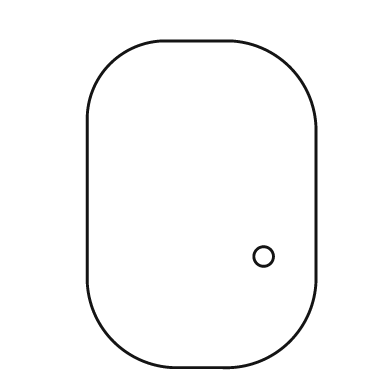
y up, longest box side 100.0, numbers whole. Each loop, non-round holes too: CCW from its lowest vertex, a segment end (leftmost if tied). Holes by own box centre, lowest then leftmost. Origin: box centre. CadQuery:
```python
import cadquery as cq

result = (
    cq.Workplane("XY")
    .moveTo(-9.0, -50.0)
    .lineTo(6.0, -50.0)
    .threePointArc((27.0, -42.0), (35.0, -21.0))
    .lineTo(35.0, 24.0)
    .threePointArc((27.0, 42.0), (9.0, 50.0))
    .lineTo(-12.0, 50.0)
    .threePointArc((-28.0, 43.0), (-35.0, 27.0))
    .lineTo(-35.0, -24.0)
    .threePointArc((-27.0, -42.0), (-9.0, -50.0))
    .close()
    .moveTo(19.0, -16.0)
    .circle(3.0)
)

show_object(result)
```